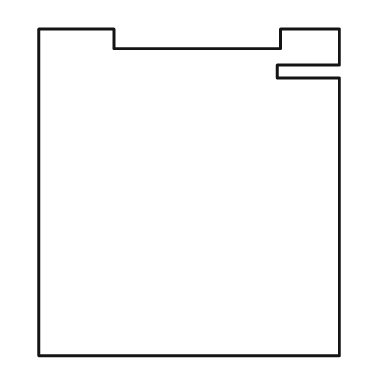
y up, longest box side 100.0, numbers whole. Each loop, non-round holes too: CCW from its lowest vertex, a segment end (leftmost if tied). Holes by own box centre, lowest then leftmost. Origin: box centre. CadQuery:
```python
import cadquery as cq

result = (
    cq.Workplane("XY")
    .moveTo(-46.0, -50.0)
    .lineTo(46.0, -50.0)
    .lineTo(46.0, 35.0)
    .lineTo(27.0, 35.0)
    .lineTo(27.0, 39.0)
    .lineTo(46.0, 39.0)
    .lineTo(46.0, 50.0)
    .lineTo(28.0, 50.0)
    .lineTo(28.0, 44.0)
    .lineTo(-23.0, 44.0)
    .lineTo(-23.0, 50.0)
    .lineTo(-46.0, 50.0)
    .close()
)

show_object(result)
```